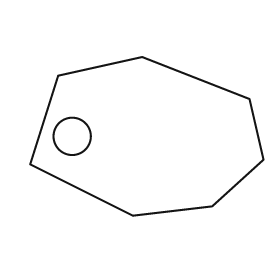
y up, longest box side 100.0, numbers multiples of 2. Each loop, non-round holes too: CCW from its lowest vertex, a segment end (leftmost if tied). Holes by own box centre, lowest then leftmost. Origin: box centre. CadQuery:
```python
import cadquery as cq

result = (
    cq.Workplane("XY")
    .moveTo(-6.0, -34.0)
    .lineTo(28.0, -30.0)
    .lineTo(50.0, -10.0)
    .lineTo(44.0, 16.0)
    .lineTo(-2.0, 34.0)
    .lineTo(-38.0, 26.0)
    .lineTo(-50.0, -12.0)
    .close()
    .moveTo(-32.0, 0.0)
    .circle(8.0)
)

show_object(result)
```